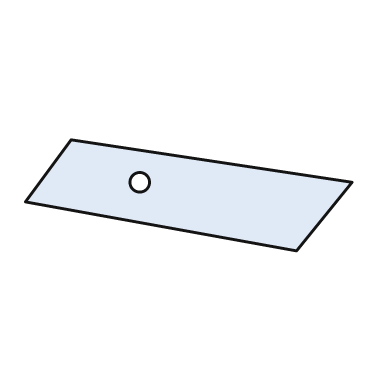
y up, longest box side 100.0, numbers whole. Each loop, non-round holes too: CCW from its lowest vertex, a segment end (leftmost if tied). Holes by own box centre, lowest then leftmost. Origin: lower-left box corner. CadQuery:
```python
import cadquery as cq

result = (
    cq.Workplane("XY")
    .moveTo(83.0, 0.0)
    .lineTo(100.0, 21.0)
    .lineTo(14.0, 34.0)
    .lineTo(0.0, 15.0)
    .close()
    .moveTo(35.0, 21.0)
    .circle(3.0)
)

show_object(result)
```